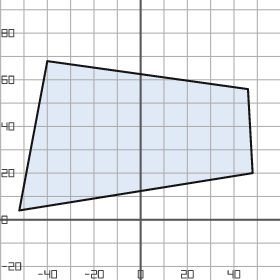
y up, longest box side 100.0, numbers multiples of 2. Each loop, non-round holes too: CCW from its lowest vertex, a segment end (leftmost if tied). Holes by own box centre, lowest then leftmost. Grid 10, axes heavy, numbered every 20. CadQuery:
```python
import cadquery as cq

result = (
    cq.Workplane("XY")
    .moveTo(-52.0, 4.0)
    .lineTo(48.0, 20.0)
    .lineTo(46.0, 56.0)
    .lineTo(-40.0, 68.0)
    .close()
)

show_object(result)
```